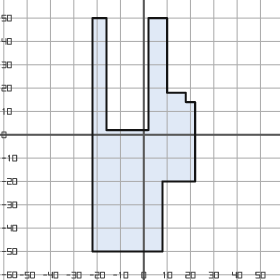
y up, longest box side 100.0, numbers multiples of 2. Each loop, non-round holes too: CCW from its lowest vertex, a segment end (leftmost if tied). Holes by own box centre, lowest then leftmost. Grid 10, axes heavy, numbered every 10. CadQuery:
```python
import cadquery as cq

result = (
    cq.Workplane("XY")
    .moveTo(-22.0, -50.0)
    .lineTo(8.0, -50.0)
    .lineTo(8.0, -20.0)
    .lineTo(22.0, -20.0)
    .lineTo(22.0, 14.0)
    .lineTo(18.0, 14.0)
    .lineTo(18.0, 18.0)
    .lineTo(10.0, 18.0)
    .lineTo(10.0, 50.0)
    .lineTo(2.0, 50.0)
    .lineTo(2.0, 2.0)
    .lineTo(-16.0, 2.0)
    .lineTo(-16.0, 50.0)
    .lineTo(-22.0, 50.0)
    .close()
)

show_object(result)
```